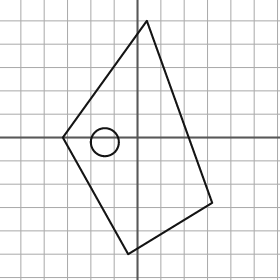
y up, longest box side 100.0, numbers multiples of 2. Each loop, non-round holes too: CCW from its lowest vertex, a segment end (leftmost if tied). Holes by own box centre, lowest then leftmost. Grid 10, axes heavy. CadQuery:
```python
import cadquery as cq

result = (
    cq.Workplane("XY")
    .moveTo(-4.0, -50.0)
    .lineTo(32.0, -28.0)
    .lineTo(4.0, 50.0)
    .lineTo(-32.0, 0.0)
    .close()
    .moveTo(-14.0, -2.0)
    .circle(6.0)
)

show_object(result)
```